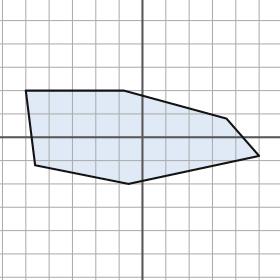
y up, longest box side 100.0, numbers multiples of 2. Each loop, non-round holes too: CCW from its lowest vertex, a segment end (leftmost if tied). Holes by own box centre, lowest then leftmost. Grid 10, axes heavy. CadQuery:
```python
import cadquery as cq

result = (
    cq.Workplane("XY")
    .moveTo(-6.0, -20.0)
    .lineTo(50.0, -8.0)
    .lineTo(36.0, 8.0)
    .lineTo(-8.0, 20.0)
    .lineTo(-50.0, 20.0)
    .lineTo(-46.0, -12.0)
    .close()
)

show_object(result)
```